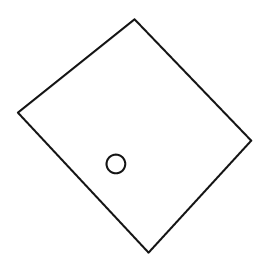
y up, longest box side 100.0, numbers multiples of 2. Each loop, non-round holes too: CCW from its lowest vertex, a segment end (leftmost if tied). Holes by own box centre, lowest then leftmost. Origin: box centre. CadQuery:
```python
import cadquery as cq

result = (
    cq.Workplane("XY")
    .moveTo(6.0, -50.0)
    .lineTo(50.0, -2.0)
    .lineTo(0.0, 50.0)
    .lineTo(-50.0, 10.0)
    .close()
    .moveTo(-8.0, -12.0)
    .circle(4.0)
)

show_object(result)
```